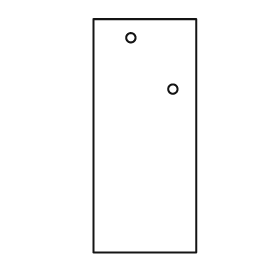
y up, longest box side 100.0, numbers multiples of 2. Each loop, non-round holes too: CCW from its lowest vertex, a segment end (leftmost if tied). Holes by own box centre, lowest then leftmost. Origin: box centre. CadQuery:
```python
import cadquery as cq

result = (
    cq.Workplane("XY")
    .moveTo(-22.0, -50.0)
    .lineTo(22.0, -50.0)
    .lineTo(22.0, 50.0)
    .lineTo(-22.0, 50.0)
    .close()
    .moveTo(12.0, 20.0)
    .circle(2.0)
    .moveTo(-6.0, 42.0)
    .circle(2.0)
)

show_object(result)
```